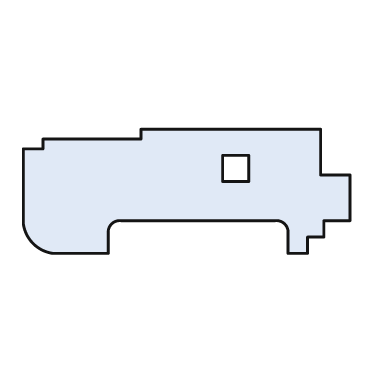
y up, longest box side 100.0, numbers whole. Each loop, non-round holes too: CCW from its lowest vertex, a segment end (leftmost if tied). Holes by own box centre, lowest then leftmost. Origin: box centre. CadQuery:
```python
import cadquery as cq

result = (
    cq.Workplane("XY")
    .moveTo(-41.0, -19.0)
    .lineTo(-24.0, -19.0)
    .lineTo(-24.0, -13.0)
    .threePointArc((-23.0, -10.0), (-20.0, -9.0))
    .lineTo(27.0, -9.0)
    .threePointArc((30.0, -10.0), (31.0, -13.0))
    .lineTo(31.0, -19.0)
    .lineTo(37.0, -19.0)
    .lineTo(37.0, -14.0)
    .lineTo(42.0, -14.0)
    .lineTo(42.0, -9.0)
    .lineTo(50.0, -9.0)
    .lineTo(50.0, 5.0)
    .lineTo(41.0, 5.0)
    .lineTo(41.0, 19.0)
    .lineTo(-14.0, 19.0)
    .lineTo(-14.0, 16.0)
    .lineTo(-44.0, 16.0)
    .lineTo(-44.0, 13.0)
    .lineTo(-50.0, 13.0)
    .lineTo(-50.0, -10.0)
    .threePointArc((-47.0, -16.0), (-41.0, -19.0))
    .close()
    .moveTo(11.0, 3.0)
    .lineTo(19.0, 3.0)
    .lineTo(19.0, 11.0)
    .lineTo(11.0, 11.0)
    .close()
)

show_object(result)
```